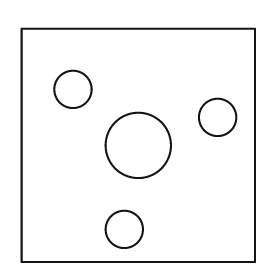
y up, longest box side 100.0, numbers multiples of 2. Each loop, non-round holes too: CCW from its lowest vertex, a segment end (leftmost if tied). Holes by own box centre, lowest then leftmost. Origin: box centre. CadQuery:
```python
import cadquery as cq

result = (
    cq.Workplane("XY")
    .moveTo(-50.0, -50.0)
    .lineTo(50.0, -50.0)
    .lineTo(50.0, 50.0)
    .lineTo(-50.0, 50.0)
    .close()
    .moveTo(-6.0, -36.0)
    .circle(8.0)
    .moveTo(0.0, 0.0)
    .circle(14.0)
    .moveTo(34.0, 12.0)
    .circle(8.0)
    .moveTo(-28.0, 24.0)
    .circle(8.0)
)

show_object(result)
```